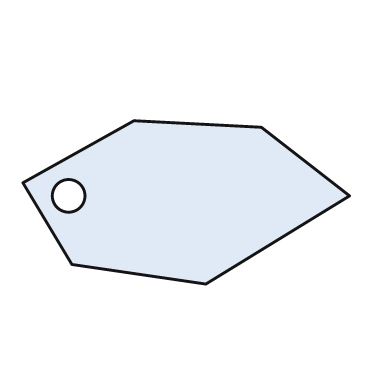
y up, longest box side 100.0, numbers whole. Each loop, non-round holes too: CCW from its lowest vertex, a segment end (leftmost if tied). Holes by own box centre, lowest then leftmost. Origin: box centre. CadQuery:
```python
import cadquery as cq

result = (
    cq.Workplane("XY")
    .moveTo(6.0, -25.0)
    .lineTo(50.0, 2.0)
    .lineTo(23.0, 23.0)
    .lineTo(-16.0, 25.0)
    .lineTo(-50.0, 6.0)
    .lineTo(-35.0, -19.0)
    .close()
    .moveTo(-36.0, 2.0)
    .circle(5.0)
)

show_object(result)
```